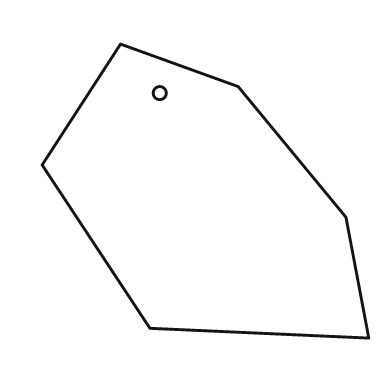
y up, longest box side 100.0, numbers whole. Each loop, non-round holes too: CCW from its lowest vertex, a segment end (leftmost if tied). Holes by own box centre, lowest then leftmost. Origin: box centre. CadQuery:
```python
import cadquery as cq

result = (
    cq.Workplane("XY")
    .moveTo(50.0, -45.0)
    .lineTo(43.0, -8.0)
    .lineTo(10.0, 32.0)
    .lineTo(-26.0, 45.0)
    .lineTo(-50.0, 8.0)
    .lineTo(-17.0, -42.0)
    .close()
    .moveTo(-14.0, 30.0)
    .circle(2.0)
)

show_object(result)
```